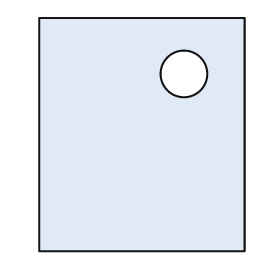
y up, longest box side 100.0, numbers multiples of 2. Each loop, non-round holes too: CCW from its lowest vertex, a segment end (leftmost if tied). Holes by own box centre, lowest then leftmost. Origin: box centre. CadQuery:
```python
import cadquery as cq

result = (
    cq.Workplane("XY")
    .moveTo(-44.0, -50.0)
    .lineTo(44.0, -50.0)
    .lineTo(44.0, 50.0)
    .lineTo(-44.0, 50.0)
    .close()
    .moveTo(18.0, 26.0)
    .circle(10.0)
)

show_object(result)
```